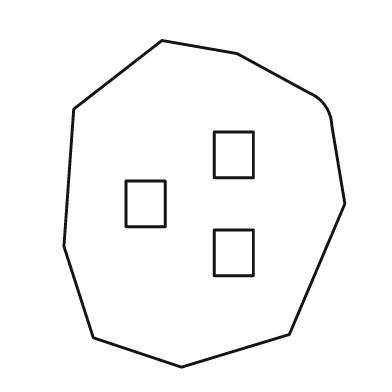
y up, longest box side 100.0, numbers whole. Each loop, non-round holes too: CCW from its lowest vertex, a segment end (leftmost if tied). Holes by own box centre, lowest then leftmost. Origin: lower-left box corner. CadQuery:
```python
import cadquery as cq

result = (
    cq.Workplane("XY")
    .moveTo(36.0, 0.0)
    .lineTo(69.0, 10.0)
    .lineTo(86.0, 50.0)
    .lineTo(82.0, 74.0)
    .threePointArc((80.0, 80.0), (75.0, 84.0))
    .lineTo(53.0, 96.0)
    .lineTo(30.0, 100.0)
    .lineTo(3.0, 79.0)
    .lineTo(0.0, 37.0)
    .lineTo(9.0, 9.0)
    .close()
    .moveTo(46.0, 28.0)
    .lineTo(58.0, 28.0)
    .lineTo(58.0, 42.0)
    .lineTo(46.0, 42.0)
    .close()
    .moveTo(19.0, 43.0)
    .lineTo(31.0, 43.0)
    .lineTo(31.0, 57.0)
    .lineTo(19.0, 57.0)
    .close()
    .moveTo(46.0, 58.0)
    .lineTo(58.0, 58.0)
    .lineTo(58.0, 72.0)
    .lineTo(46.0, 72.0)
    .close()
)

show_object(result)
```